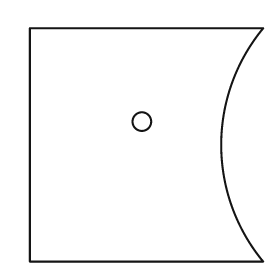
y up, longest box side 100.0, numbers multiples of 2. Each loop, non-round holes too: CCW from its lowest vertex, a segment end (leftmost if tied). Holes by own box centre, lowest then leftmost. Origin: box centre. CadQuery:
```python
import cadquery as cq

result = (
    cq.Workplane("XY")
    .moveTo(-50.0, -50.0)
    .lineTo(50.0, -50.0)
    .threePointArc((32.0, 0.0), (50.0, 50.0))
    .lineTo(-50.0, 50.0)
    .close()
    .moveTo(-2.0, 10.0)
    .circle(4.0)
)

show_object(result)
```